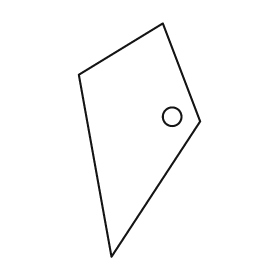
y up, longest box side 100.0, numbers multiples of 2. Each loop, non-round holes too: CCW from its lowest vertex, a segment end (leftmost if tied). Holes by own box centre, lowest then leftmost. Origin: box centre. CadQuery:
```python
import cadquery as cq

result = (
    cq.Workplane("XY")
    .moveTo(-12.0, -50.0)
    .lineTo(26.0, 8.0)
    .lineTo(10.0, 50.0)
    .lineTo(-26.0, 28.0)
    .close()
    .moveTo(14.0, 10.0)
    .circle(4.0)
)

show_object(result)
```